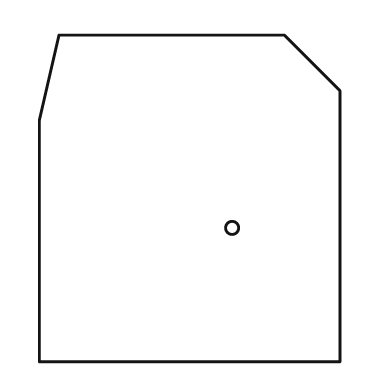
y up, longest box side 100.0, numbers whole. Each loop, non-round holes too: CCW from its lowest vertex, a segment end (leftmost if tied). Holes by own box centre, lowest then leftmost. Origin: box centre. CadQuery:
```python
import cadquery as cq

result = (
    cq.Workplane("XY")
    .moveTo(-46.0, -50.0)
    .lineTo(46.0, -50.0)
    .lineTo(46.0, 33.0)
    .lineTo(29.0, 50.0)
    .lineTo(-40.0, 50.0)
    .lineTo(-46.0, 24.0)
    .close()
    .moveTo(13.0, -9.0)
    .circle(2.0)
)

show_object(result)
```